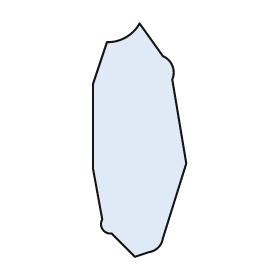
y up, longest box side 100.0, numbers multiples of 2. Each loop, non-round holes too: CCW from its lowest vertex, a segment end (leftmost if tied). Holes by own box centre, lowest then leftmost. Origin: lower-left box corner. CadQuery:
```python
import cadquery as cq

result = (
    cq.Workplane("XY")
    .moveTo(18.0, 0.0)
    .lineTo(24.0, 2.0)
    .threePointArc((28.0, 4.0), (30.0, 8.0))
    .lineTo(40.0, 40.0)
    .lineTo(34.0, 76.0)
    .threePointArc((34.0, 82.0), (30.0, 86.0))
    .lineTo(20.0, 100.0)
    .threePointArc((14.0, 94.0), (6.0, 92.0))
    .lineTo(0.0, 74.0)
    .lineTo(0.0, 38.0)
    .lineTo(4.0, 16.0)
    .threePointArc((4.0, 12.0), (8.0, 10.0))
    .close()
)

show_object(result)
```